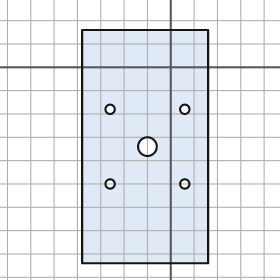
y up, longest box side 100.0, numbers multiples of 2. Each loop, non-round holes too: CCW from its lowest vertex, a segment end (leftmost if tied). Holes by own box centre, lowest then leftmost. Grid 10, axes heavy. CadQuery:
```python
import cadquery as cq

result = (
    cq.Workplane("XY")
    .moveTo(-38.0, -84.0)
    .lineTo(16.0, -84.0)
    .lineTo(16.0, 16.0)
    .lineTo(-38.0, 16.0)
    .close()
    .moveTo(-26.0, -50.0)
    .circle(2.0)
    .moveTo(6.0, -50.0)
    .circle(2.0)
    .moveTo(-10.0, -34.0)
    .circle(4.0)
    .moveTo(-26.0, -18.0)
    .circle(2.0)
    .moveTo(6.0, -18.0)
    .circle(2.0)
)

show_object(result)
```